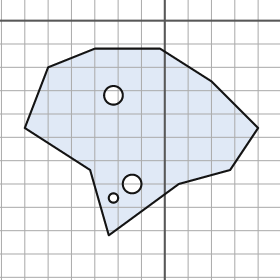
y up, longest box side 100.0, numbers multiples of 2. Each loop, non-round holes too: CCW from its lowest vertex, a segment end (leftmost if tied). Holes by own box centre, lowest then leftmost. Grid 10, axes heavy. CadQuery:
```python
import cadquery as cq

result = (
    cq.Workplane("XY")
    .moveTo(-24.0, -92.0)
    .lineTo(6.0, -70.0)
    .lineTo(28.0, -64.0)
    .lineTo(40.0, -46.0)
    .lineTo(20.0, -26.0)
    .lineTo(-2.0, -12.0)
    .lineTo(-30.0, -12.0)
    .lineTo(-50.0, -20.0)
    .lineTo(-60.0, -46.0)
    .lineTo(-32.0, -64.0)
    .close()
    .moveTo(-22.0, -76.0)
    .circle(2.0)
    .moveTo(-14.0, -70.0)
    .circle(4.0)
    .moveTo(-22.0, -32.0)
    .circle(4.0)
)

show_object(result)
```